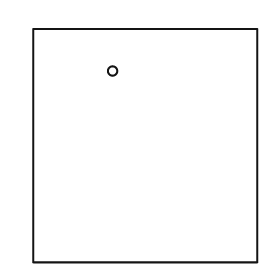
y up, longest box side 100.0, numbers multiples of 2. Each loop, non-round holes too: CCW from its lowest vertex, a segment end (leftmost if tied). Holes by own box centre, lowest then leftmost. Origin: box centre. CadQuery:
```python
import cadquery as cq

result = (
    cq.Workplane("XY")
    .moveTo(-48.0, -50.0)
    .lineTo(48.0, -50.0)
    .lineTo(48.0, 50.0)
    .lineTo(-48.0, 50.0)
    .close()
    .moveTo(-14.0, 32.0)
    .circle(2.0)
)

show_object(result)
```